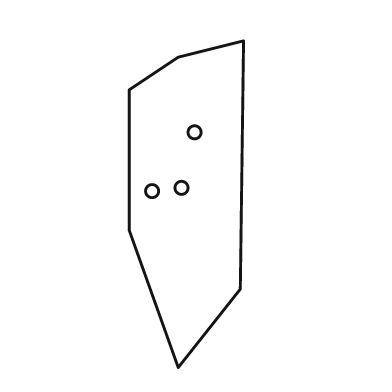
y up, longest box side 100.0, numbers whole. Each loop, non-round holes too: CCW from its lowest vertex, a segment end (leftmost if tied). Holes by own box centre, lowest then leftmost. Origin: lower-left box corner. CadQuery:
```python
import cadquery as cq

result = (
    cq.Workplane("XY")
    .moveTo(15.0, 0.0)
    .lineTo(34.0, 24.0)
    .lineTo(35.0, 100.0)
    .lineTo(15.0, 95.0)
    .lineTo(0.0, 85.0)
    .lineTo(0.0, 42.0)
    .close()
    .moveTo(7.0, 54.0)
    .circle(2.0)
    .moveTo(16.0, 55.0)
    .circle(2.0)
    .moveTo(20.0, 72.0)
    .circle(2.0)
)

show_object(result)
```